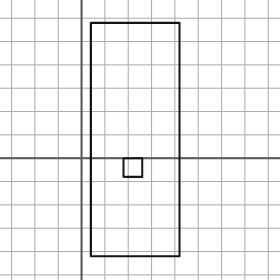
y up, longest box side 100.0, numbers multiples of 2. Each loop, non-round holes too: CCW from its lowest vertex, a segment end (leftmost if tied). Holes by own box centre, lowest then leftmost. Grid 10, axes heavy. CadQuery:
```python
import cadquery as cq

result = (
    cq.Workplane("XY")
    .moveTo(4.0, -42.0)
    .lineTo(42.0, -42.0)
    .lineTo(42.0, 58.0)
    .lineTo(4.0, 58.0)
    .close()
    .moveTo(18.0, -8.0)
    .lineTo(26.0, -8.0)
    .lineTo(26.0, 0.0)
    .lineTo(18.0, 0.0)
    .close()
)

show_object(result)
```